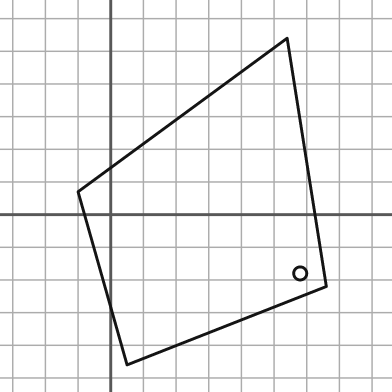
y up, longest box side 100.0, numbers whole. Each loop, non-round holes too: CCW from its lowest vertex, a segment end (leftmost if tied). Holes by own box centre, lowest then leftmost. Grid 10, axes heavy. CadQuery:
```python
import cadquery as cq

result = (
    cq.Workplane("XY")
    .moveTo(5.0, -46.0)
    .lineTo(66.0, -22.0)
    .lineTo(54.0, 54.0)
    .lineTo(-10.0, 7.0)
    .close()
    .moveTo(58.0, -18.0)
    .circle(2.0)
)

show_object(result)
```